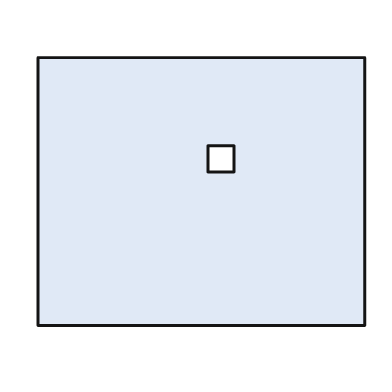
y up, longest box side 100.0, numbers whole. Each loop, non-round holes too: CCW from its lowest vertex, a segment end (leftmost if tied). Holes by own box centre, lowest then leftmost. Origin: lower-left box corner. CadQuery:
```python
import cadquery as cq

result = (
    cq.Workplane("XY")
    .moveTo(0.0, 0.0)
    .lineTo(100.0, 0.0)
    .lineTo(100.0, 82.0)
    .lineTo(0.0, 82.0)
    .close()
    .moveTo(52.0, 47.0)
    .lineTo(60.0, 47.0)
    .lineTo(60.0, 55.0)
    .lineTo(52.0, 55.0)
    .close()
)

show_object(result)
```